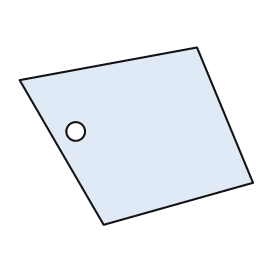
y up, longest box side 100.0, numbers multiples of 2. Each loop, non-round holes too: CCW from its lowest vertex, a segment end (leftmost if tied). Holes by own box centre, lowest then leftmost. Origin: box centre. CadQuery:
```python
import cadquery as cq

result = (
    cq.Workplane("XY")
    .moveTo(-14.0, -38.0)
    .lineTo(50.0, -20.0)
    .lineTo(26.0, 38.0)
    .lineTo(-50.0, 24.0)
    .close()
    .moveTo(-26.0, 2.0)
    .circle(4.0)
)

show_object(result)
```